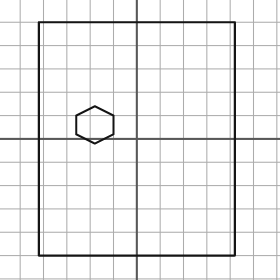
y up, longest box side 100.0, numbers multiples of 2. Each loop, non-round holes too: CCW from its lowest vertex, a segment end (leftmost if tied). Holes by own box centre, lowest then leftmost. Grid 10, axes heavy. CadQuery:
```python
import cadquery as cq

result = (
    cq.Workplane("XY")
    .moveTo(-42.0, -50.0)
    .lineTo(42.0, -50.0)
    .lineTo(42.0, 50.0)
    .lineTo(-42.0, 50.0)
    .close()
    .moveTo(-18.0, -2.0)
    .lineTo(-10.0, 2.0)
    .lineTo(-10.0, 10.0)
    .lineTo(-18.0, 14.0)
    .lineTo(-26.0, 10.0)
    .lineTo(-26.0, 2.0)
    .close()
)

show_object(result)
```